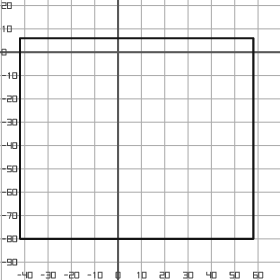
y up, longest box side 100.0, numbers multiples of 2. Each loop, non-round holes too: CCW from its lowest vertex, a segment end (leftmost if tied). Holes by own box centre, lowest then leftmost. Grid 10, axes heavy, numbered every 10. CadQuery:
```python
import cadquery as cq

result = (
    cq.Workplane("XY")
    .moveTo(-42.0, -80.0)
    .lineTo(58.0, -80.0)
    .lineTo(58.0, 6.0)
    .lineTo(-42.0, 6.0)
    .close()
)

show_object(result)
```